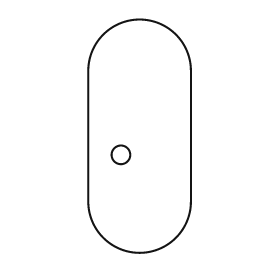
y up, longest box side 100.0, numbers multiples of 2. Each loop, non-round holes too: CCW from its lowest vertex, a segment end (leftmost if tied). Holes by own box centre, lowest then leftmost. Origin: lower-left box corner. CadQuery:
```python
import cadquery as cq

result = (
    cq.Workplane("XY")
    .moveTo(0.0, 22.0)
    .threePointArc((22.0, 0.0), (44.0, 22.0))
    .lineTo(44.0, 78.0)
    .threePointArc((22.0, 100.0), (0.0, 78.0))
    .close()
    .moveTo(14.0, 42.0)
    .circle(4.0)
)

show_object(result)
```